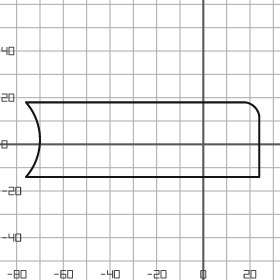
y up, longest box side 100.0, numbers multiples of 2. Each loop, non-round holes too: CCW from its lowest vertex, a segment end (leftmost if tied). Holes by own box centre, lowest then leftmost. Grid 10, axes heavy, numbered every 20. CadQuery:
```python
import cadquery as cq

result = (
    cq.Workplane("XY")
    .moveTo(-76.0, -14.0)
    .lineTo(24.0, -14.0)
    .lineTo(24.0, 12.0)
    .threePointArc((22.0, 16.0), (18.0, 18.0))
    .lineTo(-76.0, 18.0)
    .threePointArc((-70.0, 2.0), (-76.0, -14.0))
    .close()
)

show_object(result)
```